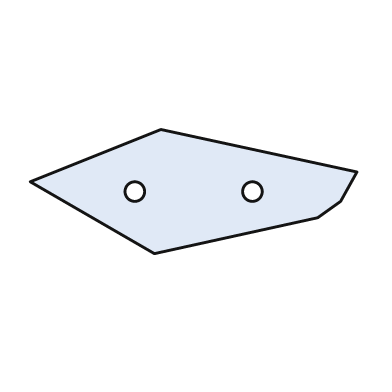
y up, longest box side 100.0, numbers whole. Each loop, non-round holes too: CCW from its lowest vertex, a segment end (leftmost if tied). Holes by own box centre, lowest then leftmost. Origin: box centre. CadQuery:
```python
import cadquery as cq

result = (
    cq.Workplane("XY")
    .moveTo(-12.0, -19.0)
    .lineTo(38.0, -8.0)
    .lineTo(45.0, -3.0)
    .lineTo(50.0, 6.0)
    .lineTo(-10.0, 19.0)
    .lineTo(-50.0, 3.0)
    .close()
    .moveTo(-18.0, 0.0)
    .circle(3.0)
    .moveTo(18.0, 0.0)
    .circle(3.0)
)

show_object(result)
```